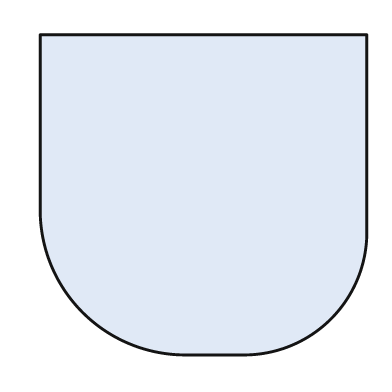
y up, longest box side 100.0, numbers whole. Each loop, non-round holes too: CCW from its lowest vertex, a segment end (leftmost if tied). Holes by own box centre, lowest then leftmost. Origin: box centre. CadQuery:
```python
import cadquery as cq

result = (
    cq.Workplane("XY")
    .moveTo(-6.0, -49.0)
    .lineTo(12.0, -49.0)
    .threePointArc((39.0, -38.0), (50.0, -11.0))
    .lineTo(50.0, 49.0)
    .lineTo(-50.0, 49.0)
    .lineTo(-50.0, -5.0)
    .threePointArc((-37.0, -36.0), (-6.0, -49.0))
    .close()
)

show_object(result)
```